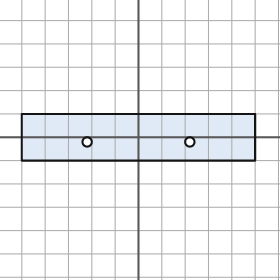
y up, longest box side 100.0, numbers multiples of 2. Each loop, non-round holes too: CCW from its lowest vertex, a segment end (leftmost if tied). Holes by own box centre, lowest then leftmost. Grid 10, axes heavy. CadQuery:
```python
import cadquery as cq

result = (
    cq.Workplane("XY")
    .moveTo(-50.0, -10.0)
    .lineTo(50.0, -10.0)
    .lineTo(50.0, 10.0)
    .lineTo(-50.0, 10.0)
    .close()
    .moveTo(-22.0, -2.0)
    .circle(2.0)
    .moveTo(22.0, -2.0)
    .circle(2.0)
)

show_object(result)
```